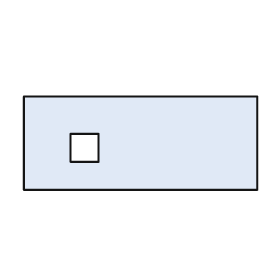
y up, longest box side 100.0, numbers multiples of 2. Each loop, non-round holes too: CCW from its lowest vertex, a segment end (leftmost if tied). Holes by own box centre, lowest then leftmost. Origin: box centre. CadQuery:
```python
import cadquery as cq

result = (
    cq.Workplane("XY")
    .moveTo(-50.0, -20.0)
    .lineTo(50.0, -20.0)
    .lineTo(50.0, 20.0)
    .lineTo(-50.0, 20.0)
    .close()
    .moveTo(-30.0, -8.0)
    .lineTo(-18.0, -8.0)
    .lineTo(-18.0, 4.0)
    .lineTo(-30.0, 4.0)
    .close()
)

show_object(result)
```